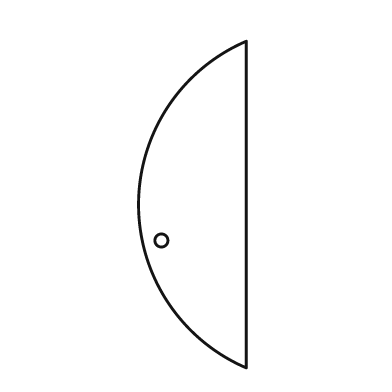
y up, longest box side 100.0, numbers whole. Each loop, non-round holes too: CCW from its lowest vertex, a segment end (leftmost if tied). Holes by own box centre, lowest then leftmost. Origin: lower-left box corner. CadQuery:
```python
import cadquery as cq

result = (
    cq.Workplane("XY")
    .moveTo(33.0, 0.0)
    .lineTo(33.0, 100.0)
    .threePointArc((0.0, 50.0), (33.0, 0.0))
    .close()
    .moveTo(7.0, 39.0)
    .circle(2.0)
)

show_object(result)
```